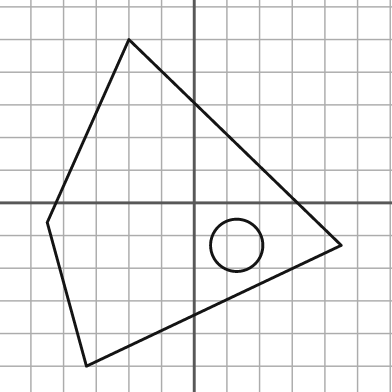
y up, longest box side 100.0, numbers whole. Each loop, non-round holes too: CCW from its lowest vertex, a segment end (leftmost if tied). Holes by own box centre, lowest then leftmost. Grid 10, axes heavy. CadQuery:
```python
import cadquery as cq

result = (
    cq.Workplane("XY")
    .moveTo(-33.0, -50.0)
    .lineTo(45.0, -13.0)
    .lineTo(-20.0, 50.0)
    .lineTo(-45.0, -6.0)
    .close()
    .moveTo(13.0, -13.0)
    .circle(8.0)
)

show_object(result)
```